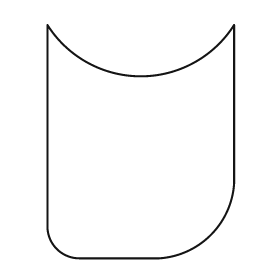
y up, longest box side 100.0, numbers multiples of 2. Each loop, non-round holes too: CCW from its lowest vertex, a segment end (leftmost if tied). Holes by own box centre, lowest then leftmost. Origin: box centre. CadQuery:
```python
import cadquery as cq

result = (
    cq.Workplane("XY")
    .moveTo(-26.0, -50.0)
    .lineTo(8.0, -50.0)
    .threePointArc((30.0, -40.0), (40.0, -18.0))
    .lineTo(40.0, 50.0)
    .threePointArc((0.0, 28.0), (-40.0, 50.0))
    .lineTo(-40.0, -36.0)
    .threePointArc((-36.0, -46.0), (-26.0, -50.0))
    .close()
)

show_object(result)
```